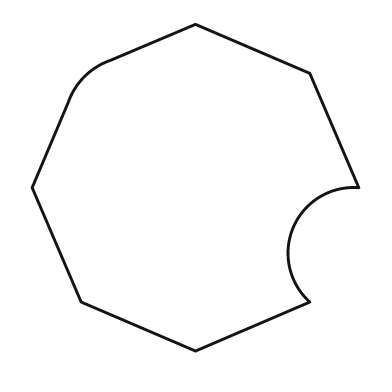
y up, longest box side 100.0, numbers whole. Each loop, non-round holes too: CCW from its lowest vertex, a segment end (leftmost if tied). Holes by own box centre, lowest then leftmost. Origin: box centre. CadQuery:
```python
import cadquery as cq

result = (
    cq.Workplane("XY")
    .moveTo(0.0, -50.0)
    .lineTo(35.0, -35.0)
    .threePointArc((30.0, -12.0), (50.0, 0.0))
    .lineTo(35.0, 35.0)
    .lineTo(0.0, 50.0)
    .lineTo(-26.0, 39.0)
    .threePointArc((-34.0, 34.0), (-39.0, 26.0))
    .lineTo(-50.0, 0.0)
    .lineTo(-35.0, -35.0)
    .close()
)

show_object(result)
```